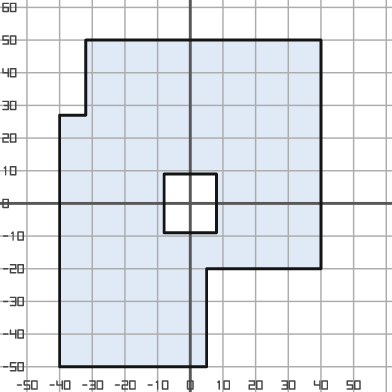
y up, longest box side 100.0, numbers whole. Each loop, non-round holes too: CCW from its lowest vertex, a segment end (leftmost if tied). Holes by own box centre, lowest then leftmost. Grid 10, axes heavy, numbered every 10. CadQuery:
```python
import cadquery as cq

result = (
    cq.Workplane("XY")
    .moveTo(-40.0, -50.0)
    .lineTo(5.0, -50.0)
    .lineTo(5.0, -20.0)
    .lineTo(40.0, -20.0)
    .lineTo(40.0, 50.0)
    .lineTo(-32.0, 50.0)
    .lineTo(-32.0, 27.0)
    .lineTo(-40.0, 27.0)
    .close()
    .moveTo(-8.0, -9.0)
    .lineTo(8.0, -9.0)
    .lineTo(8.0, 9.0)
    .lineTo(-8.0, 9.0)
    .close()
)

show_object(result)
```